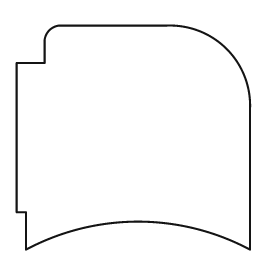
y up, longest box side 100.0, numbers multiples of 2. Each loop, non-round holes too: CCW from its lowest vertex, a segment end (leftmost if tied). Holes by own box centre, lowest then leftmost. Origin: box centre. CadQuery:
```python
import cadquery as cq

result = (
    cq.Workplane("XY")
    .moveTo(-46.0, -48.0)
    .threePointArc((2.0, -36.0), (50.0, -48.0))
    .lineTo(50.0, 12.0)
    .threePointArc((40.0, 38.0), (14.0, 48.0))
    .lineTo(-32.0, 48.0)
    .threePointArc((-36.0, 46.0), (-38.0, 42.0))
    .lineTo(-38.0, 32.0)
    .lineTo(-50.0, 32.0)
    .lineTo(-50.0, -32.0)
    .lineTo(-46.0, -32.0)
    .close()
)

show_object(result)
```